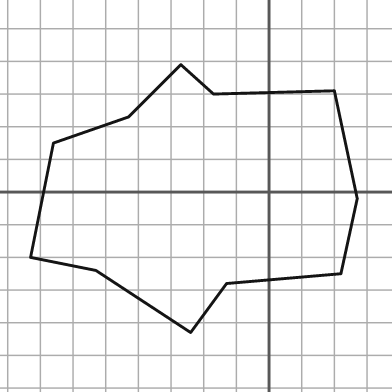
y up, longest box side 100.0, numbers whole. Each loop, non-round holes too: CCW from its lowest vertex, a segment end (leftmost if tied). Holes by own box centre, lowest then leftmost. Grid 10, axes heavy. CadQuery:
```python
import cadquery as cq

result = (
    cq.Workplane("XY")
    .moveTo(-24.0, -43.0)
    .lineTo(-13.0, -28.0)
    .lineTo(22.0, -25.0)
    .lineTo(27.0, -2.0)
    .lineTo(20.0, 31.0)
    .lineTo(-17.0, 30.0)
    .lineTo(-27.0, 39.0)
    .lineTo(-43.0, 23.0)
    .lineTo(-66.0, 15.0)
    .lineTo(-73.0, -20.0)
    .lineTo(-53.0, -24.0)
    .close()
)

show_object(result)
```